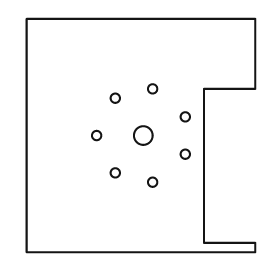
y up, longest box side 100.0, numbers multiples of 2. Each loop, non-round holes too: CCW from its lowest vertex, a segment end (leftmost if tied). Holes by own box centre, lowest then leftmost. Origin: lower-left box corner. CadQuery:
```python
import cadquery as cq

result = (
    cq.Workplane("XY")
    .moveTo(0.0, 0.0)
    .lineTo(98.0, 0.0)
    .lineTo(98.0, 4.0)
    .lineTo(76.0, 4.0)
    .lineTo(76.0, 70.0)
    .lineTo(98.0, 70.0)
    .lineTo(98.0, 100.0)
    .lineTo(0.0, 100.0)
    .close()
    .moveTo(54.0, 30.0)
    .circle(2.0)
    .moveTo(38.0, 34.0)
    .circle(2.0)
    .moveTo(68.0, 42.0)
    .circle(2.0)
    .moveTo(30.0, 50.0)
    .circle(2.0)
    .moveTo(50.0, 50.0)
    .circle(4.0)
    .moveTo(68.0, 58.0)
    .circle(2.0)
    .moveTo(38.0, 66.0)
    .circle(2.0)
    .moveTo(54.0, 70.0)
    .circle(2.0)
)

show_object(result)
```